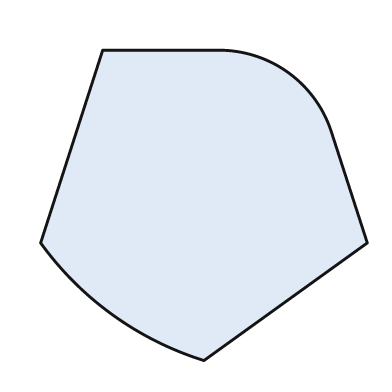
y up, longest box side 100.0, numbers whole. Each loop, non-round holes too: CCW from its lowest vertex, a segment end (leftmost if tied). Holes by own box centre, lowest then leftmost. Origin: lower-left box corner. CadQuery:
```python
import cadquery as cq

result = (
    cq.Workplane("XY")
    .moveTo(50.0, 0.0)
    .lineTo(100.0, 36.0)
    .lineTo(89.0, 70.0)
    .threePointArc((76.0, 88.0), (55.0, 95.0))
    .lineTo(19.0, 95.0)
    .lineTo(0.0, 36.0)
    .threePointArc((22.0, 14.0), (50.0, 0.0))
    .close()
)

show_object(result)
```